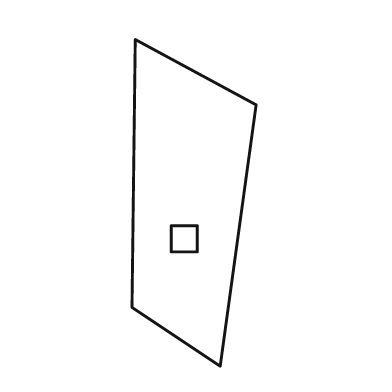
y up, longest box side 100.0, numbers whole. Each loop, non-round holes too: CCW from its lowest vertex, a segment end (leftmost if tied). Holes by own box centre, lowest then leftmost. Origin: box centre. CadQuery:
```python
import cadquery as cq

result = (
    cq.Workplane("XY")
    .moveTo(8.0, -50.0)
    .lineTo(19.0, 30.0)
    .lineTo(-18.0, 50.0)
    .lineTo(-19.0, -32.0)
    .close()
    .moveTo(-7.0, -15.0)
    .lineTo(1.0, -15.0)
    .lineTo(1.0, -7.0)
    .lineTo(-7.0, -7.0)
    .close()
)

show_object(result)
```